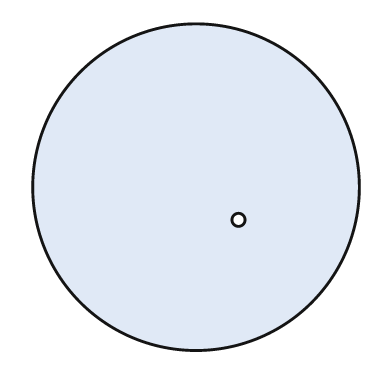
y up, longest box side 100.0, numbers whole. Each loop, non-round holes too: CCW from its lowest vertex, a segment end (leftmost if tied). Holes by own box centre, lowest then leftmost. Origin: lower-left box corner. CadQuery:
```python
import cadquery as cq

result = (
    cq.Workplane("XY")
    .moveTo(50.0, 50.0)
    .circle(50.0)
    .moveTo(63.0, 40.0)
    .circle(2.0)
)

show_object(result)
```